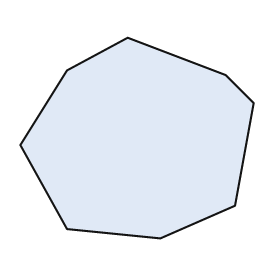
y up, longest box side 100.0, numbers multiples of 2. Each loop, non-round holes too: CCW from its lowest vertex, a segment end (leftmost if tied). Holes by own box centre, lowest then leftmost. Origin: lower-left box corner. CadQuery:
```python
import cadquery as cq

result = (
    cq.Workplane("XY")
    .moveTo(60.0, 0.0)
    .lineTo(92.0, 14.0)
    .lineTo(100.0, 58.0)
    .lineTo(88.0, 70.0)
    .lineTo(46.0, 86.0)
    .lineTo(20.0, 72.0)
    .lineTo(0.0, 40.0)
    .lineTo(20.0, 4.0)
    .close()
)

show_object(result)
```